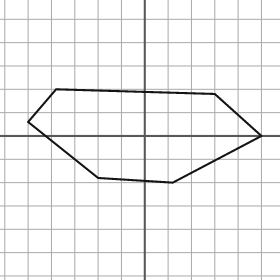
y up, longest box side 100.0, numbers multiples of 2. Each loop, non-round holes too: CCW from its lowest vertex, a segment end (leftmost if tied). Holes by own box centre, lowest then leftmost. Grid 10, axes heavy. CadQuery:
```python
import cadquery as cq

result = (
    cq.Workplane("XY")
    .moveTo(12.0, -20.0)
    .lineTo(50.0, 0.0)
    .lineTo(30.0, 18.0)
    .lineTo(-38.0, 20.0)
    .lineTo(-50.0, 6.0)
    .lineTo(-20.0, -18.0)
    .close()
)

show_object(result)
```